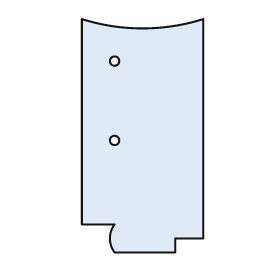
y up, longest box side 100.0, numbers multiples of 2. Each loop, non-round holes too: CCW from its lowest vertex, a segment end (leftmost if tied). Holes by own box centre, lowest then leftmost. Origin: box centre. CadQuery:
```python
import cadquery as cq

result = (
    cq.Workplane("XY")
    .moveTo(-12.0, -50.0)
    .lineTo(14.0, -50.0)
    .lineTo(14.0, -44.0)
    .lineTo(26.0, -44.0)
    .lineTo(26.0, 50.0)
    .threePointArc((0.0, 46.0), (-26.0, 50.0))
    .lineTo(-26.0, -38.0)
    .lineTo(-12.0, -38.0)
    .threePointArc((-14.0, -44.0), (-12.0, -50.0))
    .close()
    .moveTo(-12.0, -2.0)
    .circle(2.0)
    .moveTo(-12.0, 32.0)
    .circle(2.0)
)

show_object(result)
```